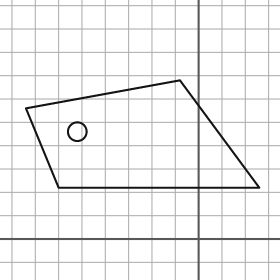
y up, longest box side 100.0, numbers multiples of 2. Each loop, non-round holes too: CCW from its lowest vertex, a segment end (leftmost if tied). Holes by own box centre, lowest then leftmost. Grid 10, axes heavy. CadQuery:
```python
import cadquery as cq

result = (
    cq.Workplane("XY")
    .moveTo(-60.0, 22.0)
    .lineTo(26.0, 22.0)
    .lineTo(-8.0, 68.0)
    .lineTo(-74.0, 56.0)
    .close()
    .moveTo(-52.0, 46.0)
    .circle(4.0)
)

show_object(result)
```